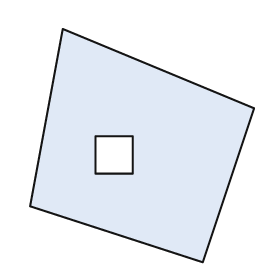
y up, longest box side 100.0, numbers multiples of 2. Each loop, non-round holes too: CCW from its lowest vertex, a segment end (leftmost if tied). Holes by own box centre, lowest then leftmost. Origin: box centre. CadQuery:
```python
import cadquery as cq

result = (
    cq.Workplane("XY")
    .moveTo(26.0, -50.0)
    .lineTo(48.0, 16.0)
    .lineTo(-34.0, 50.0)
    .lineTo(-48.0, -26.0)
    .close()
    .moveTo(-20.0, -12.0)
    .lineTo(-4.0, -12.0)
    .lineTo(-4.0, 4.0)
    .lineTo(-20.0, 4.0)
    .close()
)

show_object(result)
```